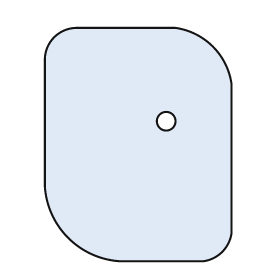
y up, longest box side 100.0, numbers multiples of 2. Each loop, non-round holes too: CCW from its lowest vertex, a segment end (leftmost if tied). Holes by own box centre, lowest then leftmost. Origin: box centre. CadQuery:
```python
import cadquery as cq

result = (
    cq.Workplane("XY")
    .moveTo(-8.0, -50.0)
    .lineTo(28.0, -50.0)
    .threePointArc((36.0, -46.0), (40.0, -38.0))
    .lineTo(40.0, 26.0)
    .threePointArc((32.0, 42.0), (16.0, 50.0))
    .lineTo(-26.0, 50.0)
    .threePointArc((-36.0, 46.0), (-40.0, 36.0))
    .lineTo(-40.0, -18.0)
    .threePointArc((-30.0, -40.0), (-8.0, -50.0))
    .close()
    .moveTo(12.0, 10.0)
    .circle(4.0)
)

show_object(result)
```